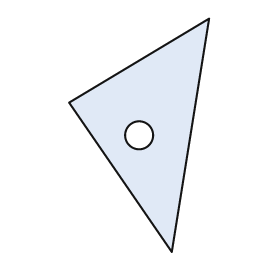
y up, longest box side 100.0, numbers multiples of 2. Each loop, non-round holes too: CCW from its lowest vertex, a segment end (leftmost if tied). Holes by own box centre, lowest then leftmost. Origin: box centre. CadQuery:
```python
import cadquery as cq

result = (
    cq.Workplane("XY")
    .moveTo(14.0, -50.0)
    .lineTo(30.0, 50.0)
    .lineTo(-30.0, 14.0)
    .close()
    .moveTo(0.0, 0.0)
    .circle(6.0)
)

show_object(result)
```